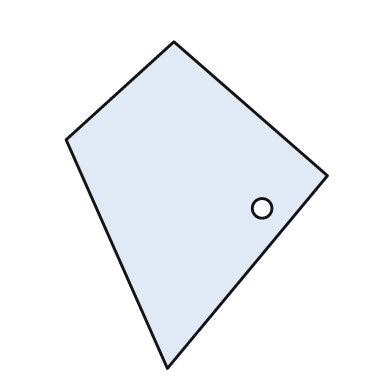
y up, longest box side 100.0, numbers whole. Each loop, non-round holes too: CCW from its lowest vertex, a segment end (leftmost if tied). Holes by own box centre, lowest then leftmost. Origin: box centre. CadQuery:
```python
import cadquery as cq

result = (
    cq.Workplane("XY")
    .moveTo(-9.0, -50.0)
    .lineTo(40.0, 9.0)
    .lineTo(-7.0, 50.0)
    .lineTo(-40.0, 20.0)
    .close()
    .moveTo(20.0, -1.0)
    .circle(3.0)
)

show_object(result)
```